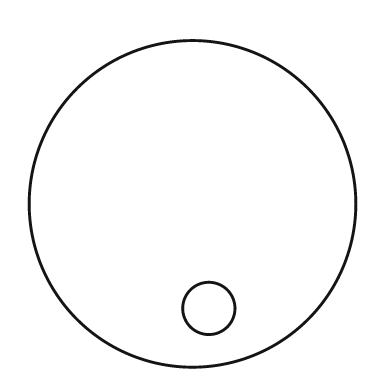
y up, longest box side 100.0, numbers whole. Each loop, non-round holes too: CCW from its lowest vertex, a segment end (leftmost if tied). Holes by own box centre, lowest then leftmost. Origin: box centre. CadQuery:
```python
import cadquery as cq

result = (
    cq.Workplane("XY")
    .moveTo(0.0, 0.0)
    .circle(50.0)
    .moveTo(5.0, -32.0)
    .circle(8.0)
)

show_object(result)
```